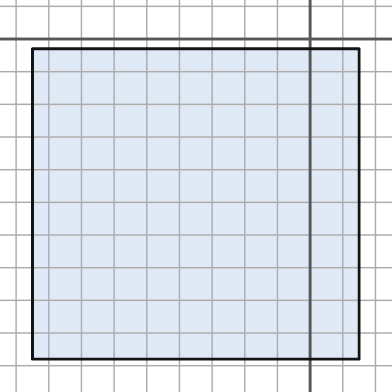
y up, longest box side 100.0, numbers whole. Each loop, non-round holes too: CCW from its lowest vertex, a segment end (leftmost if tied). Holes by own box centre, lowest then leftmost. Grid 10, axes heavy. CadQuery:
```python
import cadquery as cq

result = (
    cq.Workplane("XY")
    .moveTo(-85.0, -98.0)
    .lineTo(15.0, -98.0)
    .lineTo(15.0, -3.0)
    .lineTo(-85.0, -3.0)
    .close()
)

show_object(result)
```